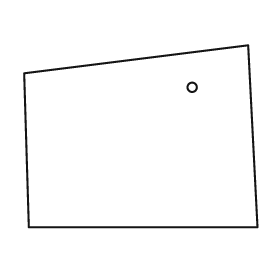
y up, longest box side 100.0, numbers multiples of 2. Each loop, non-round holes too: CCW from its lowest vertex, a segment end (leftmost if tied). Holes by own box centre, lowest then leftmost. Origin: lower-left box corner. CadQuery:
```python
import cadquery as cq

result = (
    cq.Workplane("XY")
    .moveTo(2.0, 0.0)
    .lineTo(100.0, 0.0)
    .lineTo(96.0, 78.0)
    .lineTo(0.0, 66.0)
    .close()
    .moveTo(72.0, 60.0)
    .circle(2.0)
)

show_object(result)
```